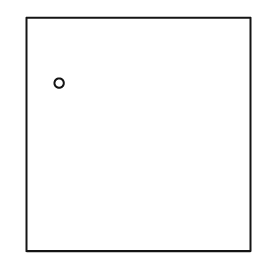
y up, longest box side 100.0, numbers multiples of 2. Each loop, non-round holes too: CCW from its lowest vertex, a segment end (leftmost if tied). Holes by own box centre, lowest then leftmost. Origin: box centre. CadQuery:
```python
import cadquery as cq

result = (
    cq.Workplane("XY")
    .moveTo(-48.0, -50.0)
    .lineTo(48.0, -50.0)
    .lineTo(48.0, 50.0)
    .lineTo(-48.0, 50.0)
    .close()
    .moveTo(-34.0, 22.0)
    .circle(2.0)
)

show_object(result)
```